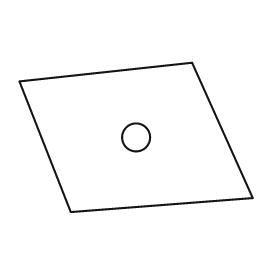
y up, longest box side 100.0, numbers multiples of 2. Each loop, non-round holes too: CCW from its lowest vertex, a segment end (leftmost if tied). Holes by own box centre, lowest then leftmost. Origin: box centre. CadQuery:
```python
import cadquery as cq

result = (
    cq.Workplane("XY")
    .moveTo(-28.0, -32.0)
    .lineTo(50.0, -26.0)
    .lineTo(24.0, 32.0)
    .lineTo(-50.0, 24.0)
    .close()
    .moveTo(0.0, 0.0)
    .circle(6.0)
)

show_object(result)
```